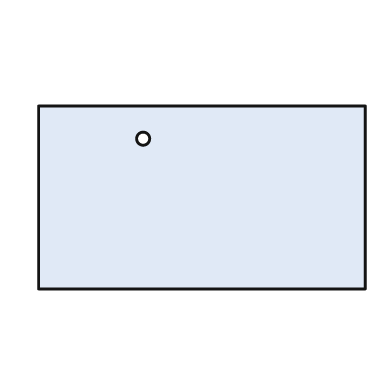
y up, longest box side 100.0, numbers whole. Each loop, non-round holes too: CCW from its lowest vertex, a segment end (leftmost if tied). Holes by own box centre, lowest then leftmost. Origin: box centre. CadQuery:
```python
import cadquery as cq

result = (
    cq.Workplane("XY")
    .moveTo(-50.0, -28.0)
    .lineTo(50.0, -28.0)
    .lineTo(50.0, 28.0)
    .lineTo(-50.0, 28.0)
    .close()
    .moveTo(-18.0, 18.0)
    .circle(2.0)
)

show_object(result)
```